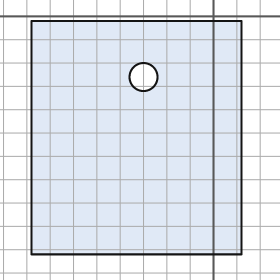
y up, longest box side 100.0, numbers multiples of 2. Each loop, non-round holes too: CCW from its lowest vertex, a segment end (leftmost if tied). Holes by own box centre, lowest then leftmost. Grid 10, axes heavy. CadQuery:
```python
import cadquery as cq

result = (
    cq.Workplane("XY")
    .moveTo(-78.0, -102.0)
    .lineTo(12.0, -102.0)
    .lineTo(12.0, -2.0)
    .lineTo(-78.0, -2.0)
    .close()
    .moveTo(-30.0, -26.0)
    .circle(6.0)
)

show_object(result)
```